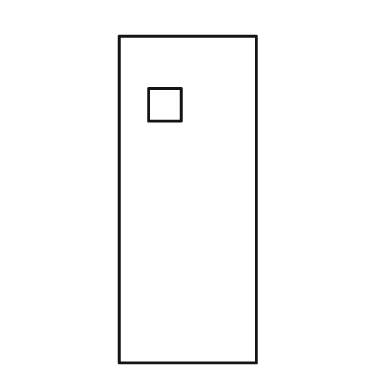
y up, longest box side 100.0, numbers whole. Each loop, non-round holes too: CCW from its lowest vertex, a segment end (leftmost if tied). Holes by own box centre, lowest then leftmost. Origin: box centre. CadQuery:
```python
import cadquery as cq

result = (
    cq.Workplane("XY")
    .moveTo(-21.0, -50.0)
    .lineTo(21.0, -50.0)
    .lineTo(21.0, 50.0)
    .lineTo(-21.0, 50.0)
    .close()
    .moveTo(-12.0, 24.0)
    .lineTo(-2.0, 24.0)
    .lineTo(-2.0, 34.0)
    .lineTo(-12.0, 34.0)
    .close()
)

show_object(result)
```